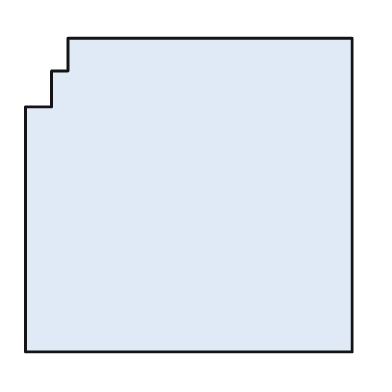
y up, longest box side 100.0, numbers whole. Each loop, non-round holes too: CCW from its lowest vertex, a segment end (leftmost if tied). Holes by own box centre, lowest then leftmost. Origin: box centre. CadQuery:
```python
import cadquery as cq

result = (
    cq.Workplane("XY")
    .moveTo(-50.0, -48.0)
    .lineTo(50.0, -48.0)
    .lineTo(50.0, 48.0)
    .lineTo(-37.0, 48.0)
    .lineTo(-37.0, 38.0)
    .lineTo(-42.0, 38.0)
    .lineTo(-42.0, 27.0)
    .lineTo(-50.0, 27.0)
    .close()
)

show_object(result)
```